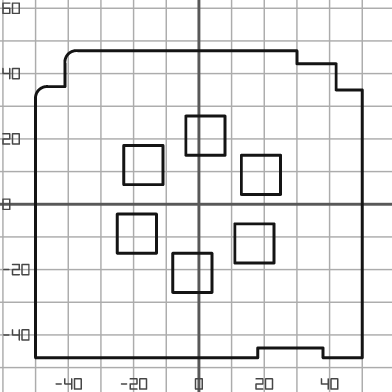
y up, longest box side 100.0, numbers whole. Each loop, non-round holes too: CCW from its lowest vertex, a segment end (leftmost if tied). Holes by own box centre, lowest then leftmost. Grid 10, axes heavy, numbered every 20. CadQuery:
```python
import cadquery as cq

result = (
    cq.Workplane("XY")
    .moveTo(-50.0, -47.0)
    .lineTo(18.0, -47.0)
    .lineTo(18.0, -44.0)
    .lineTo(38.0, -44.0)
    .lineTo(38.0, -47.0)
    .lineTo(50.0, -47.0)
    .lineTo(50.0, 35.0)
    .lineTo(42.0, 35.0)
    .lineTo(42.0, 43.0)
    .lineTo(30.0, 43.0)
    .lineTo(30.0, 47.0)
    .lineTo(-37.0, 47.0)
    .threePointArc((-40.0, 46.0), (-41.0, 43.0))
    .lineTo(-41.0, 36.0)
    .lineTo(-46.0, 36.0)
    .threePointArc((-49.0, 35.0), (-50.0, 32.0))
    .close()
    .moveTo(-8.0, -27.0)
    .lineTo(4.0, -27.0)
    .lineTo(4.0, -15.0)
    .lineTo(-8.0, -15.0)
    .close()
    .moveTo(11.0, -18.0)
    .lineTo(23.0, -18.0)
    .lineTo(23.0, -6.0)
    .lineTo(11.0, -6.0)
    .close()
    .moveTo(-25.0, -15.0)
    .lineTo(-13.0, -15.0)
    .lineTo(-13.0, -3.0)
    .lineTo(-25.0, -3.0)
    .close()
    .moveTo(13.0, 3.0)
    .lineTo(25.0, 3.0)
    .lineTo(25.0, 15.0)
    .lineTo(13.0, 15.0)
    .close()
    .moveTo(-23.0, 6.0)
    .lineTo(-11.0, 6.0)
    .lineTo(-11.0, 18.0)
    .lineTo(-23.0, 18.0)
    .close()
    .moveTo(-4.0, 15.0)
    .lineTo(8.0, 15.0)
    .lineTo(8.0, 27.0)
    .lineTo(-4.0, 27.0)
    .close()
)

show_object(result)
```